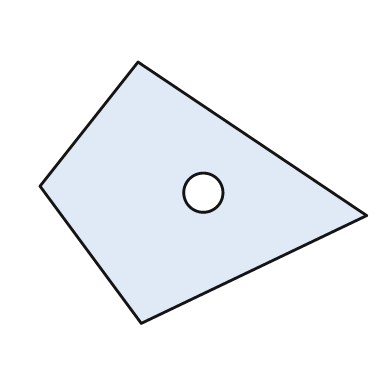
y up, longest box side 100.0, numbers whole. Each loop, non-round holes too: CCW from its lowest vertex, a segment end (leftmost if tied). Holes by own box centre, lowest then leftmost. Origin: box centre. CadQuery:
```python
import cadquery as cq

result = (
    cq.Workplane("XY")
    .moveTo(-19.0, -40.0)
    .lineTo(50.0, -7.0)
    .lineTo(-20.0, 40.0)
    .lineTo(-50.0, 2.0)
    .close()
    .moveTo(0.0, 0.0)
    .circle(6.0)
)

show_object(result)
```